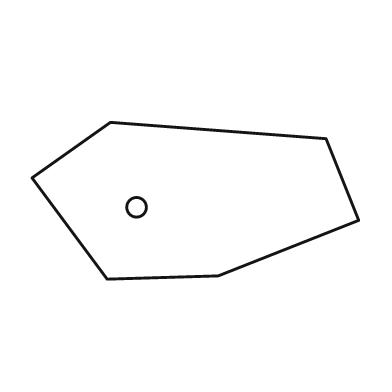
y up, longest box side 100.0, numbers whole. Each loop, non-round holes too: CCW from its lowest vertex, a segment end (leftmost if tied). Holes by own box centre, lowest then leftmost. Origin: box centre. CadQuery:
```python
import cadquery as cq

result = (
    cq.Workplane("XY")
    .moveTo(-27.0, -24.0)
    .lineTo(7.0, -23.0)
    .lineTo(50.0, -6.0)
    .lineTo(40.0, 19.0)
    .lineTo(-26.0, 24.0)
    .lineTo(-50.0, 7.0)
    .close()
    .moveTo(-18.0, -2.0)
    .circle(3.0)
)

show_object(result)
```